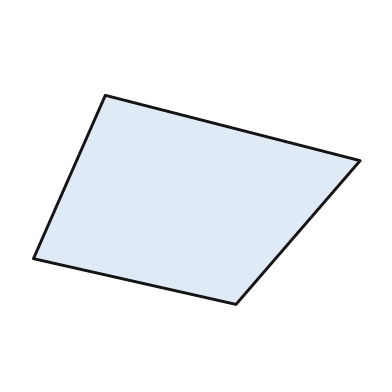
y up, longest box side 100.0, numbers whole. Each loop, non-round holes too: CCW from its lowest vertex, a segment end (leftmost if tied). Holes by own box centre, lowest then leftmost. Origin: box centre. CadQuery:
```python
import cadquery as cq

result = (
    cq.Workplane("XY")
    .moveTo(12.0, -32.0)
    .lineTo(50.0, 12.0)
    .lineTo(-28.0, 32.0)
    .lineTo(-50.0, -18.0)
    .close()
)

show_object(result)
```